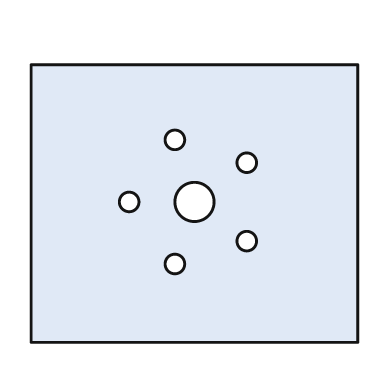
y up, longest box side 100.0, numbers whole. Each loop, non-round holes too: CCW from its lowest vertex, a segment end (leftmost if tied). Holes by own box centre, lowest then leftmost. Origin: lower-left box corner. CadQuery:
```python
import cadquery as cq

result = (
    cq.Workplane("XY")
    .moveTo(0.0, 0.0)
    .lineTo(100.0, 0.0)
    .lineTo(100.0, 85.0)
    .lineTo(0.0, 85.0)
    .close()
    .moveTo(44.0, 24.0)
    .circle(3.0)
    .moveTo(66.0, 31.0)
    .circle(3.0)
    .moveTo(30.0, 43.0)
    .circle(3.0)
    .moveTo(50.0, 43.0)
    .circle(6.0)
    .moveTo(66.0, 55.0)
    .circle(3.0)
    .moveTo(44.0, 62.0)
    .circle(3.0)
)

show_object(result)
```